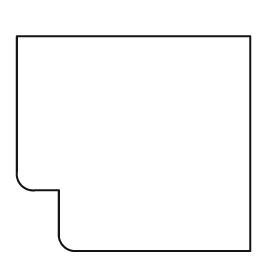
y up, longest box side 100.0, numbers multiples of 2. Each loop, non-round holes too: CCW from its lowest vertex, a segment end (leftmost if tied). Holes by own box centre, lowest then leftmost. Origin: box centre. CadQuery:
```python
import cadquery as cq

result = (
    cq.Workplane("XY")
    .moveTo(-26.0, -46.0)
    .lineTo(50.0, -46.0)
    .lineTo(50.0, 46.0)
    .lineTo(-50.0, 46.0)
    .lineTo(-50.0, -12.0)
    .threePointArc((-48.0, -18.0), (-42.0, -20.0))
    .lineTo(-32.0, -20.0)
    .lineTo(-32.0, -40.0)
    .threePointArc((-30.0, -44.0), (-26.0, -46.0))
    .close()
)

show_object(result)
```